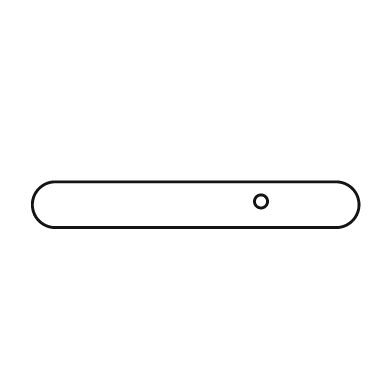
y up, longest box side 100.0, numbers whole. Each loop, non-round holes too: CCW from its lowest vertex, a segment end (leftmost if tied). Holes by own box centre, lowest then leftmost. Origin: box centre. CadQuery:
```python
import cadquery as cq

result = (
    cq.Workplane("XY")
    .moveTo(-43.0, -7.0)
    .lineTo(43.0, -7.0)
    .threePointArc((50.0, 0.0), (43.0, 7.0))
    .lineTo(-43.0, 7.0)
    .threePointArc((-50.0, 0.0), (-43.0, -7.0))
    .close()
    .moveTo(20.0, 1.0)
    .circle(2.0)
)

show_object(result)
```